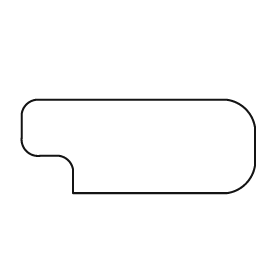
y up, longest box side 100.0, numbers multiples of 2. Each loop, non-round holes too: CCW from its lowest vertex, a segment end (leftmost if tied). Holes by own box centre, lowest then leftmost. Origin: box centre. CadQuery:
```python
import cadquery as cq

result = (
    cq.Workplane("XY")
    .moveTo(-28.0, -20.0)
    .lineTo(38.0, -20.0)
    .threePointArc((46.0, -16.0), (50.0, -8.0))
    .lineTo(50.0, 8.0)
    .threePointArc((46.0, 16.0), (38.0, 20.0))
    .lineTo(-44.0, 20.0)
    .threePointArc((-48.0, 18.0), (-50.0, 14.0))
    .lineTo(-50.0, 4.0)
    .threePointArc((-48.0, -2.0), (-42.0, -4.0))
    .lineTo(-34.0, -4.0)
    .threePointArc((-30.0, -6.0), (-28.0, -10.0))
    .close()
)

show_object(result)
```